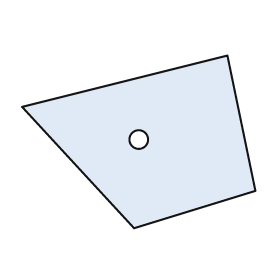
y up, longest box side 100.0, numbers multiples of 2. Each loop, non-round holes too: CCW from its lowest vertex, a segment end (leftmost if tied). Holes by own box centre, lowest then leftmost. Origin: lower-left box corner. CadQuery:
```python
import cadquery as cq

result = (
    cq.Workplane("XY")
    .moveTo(48.0, 0.0)
    .lineTo(100.0, 16.0)
    .lineTo(88.0, 74.0)
    .lineTo(0.0, 52.0)
    .close()
    .moveTo(50.0, 38.0)
    .circle(4.0)
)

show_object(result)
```